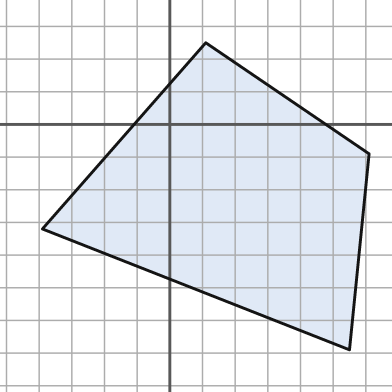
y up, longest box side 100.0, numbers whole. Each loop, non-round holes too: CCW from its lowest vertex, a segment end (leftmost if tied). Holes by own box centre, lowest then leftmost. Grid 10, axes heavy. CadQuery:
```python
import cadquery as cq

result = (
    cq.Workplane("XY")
    .moveTo(55.0, -69.0)
    .lineTo(61.0, -9.0)
    .lineTo(11.0, 25.0)
    .lineTo(-39.0, -32.0)
    .close()
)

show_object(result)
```